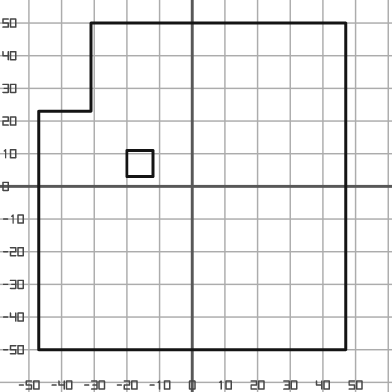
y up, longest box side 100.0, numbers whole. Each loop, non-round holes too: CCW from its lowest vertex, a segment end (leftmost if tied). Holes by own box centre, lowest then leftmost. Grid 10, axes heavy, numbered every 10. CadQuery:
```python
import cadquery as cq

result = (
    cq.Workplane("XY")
    .moveTo(-47.0, -50.0)
    .lineTo(47.0, -50.0)
    .lineTo(47.0, 50.0)
    .lineTo(-31.0, 50.0)
    .lineTo(-31.0, 23.0)
    .lineTo(-47.0, 23.0)
    .close()
    .moveTo(-20.0, 3.0)
    .lineTo(-12.0, 3.0)
    .lineTo(-12.0, 11.0)
    .lineTo(-20.0, 11.0)
    .close()
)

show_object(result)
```